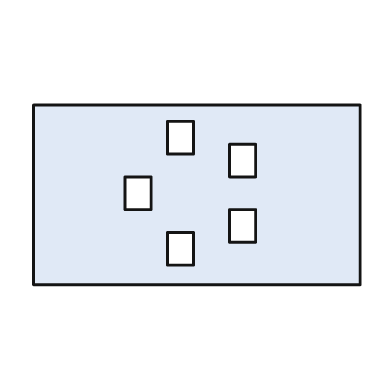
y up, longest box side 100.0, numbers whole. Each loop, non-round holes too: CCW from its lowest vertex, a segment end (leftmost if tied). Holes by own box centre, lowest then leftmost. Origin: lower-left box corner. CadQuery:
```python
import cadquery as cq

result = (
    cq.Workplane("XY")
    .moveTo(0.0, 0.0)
    .lineTo(100.0, 0.0)
    .lineTo(100.0, 55.0)
    .lineTo(0.0, 55.0)
    .close()
    .moveTo(41.0, 6.0)
    .lineTo(49.0, 6.0)
    .lineTo(49.0, 16.0)
    .lineTo(41.0, 16.0)
    .close()
    .moveTo(60.0, 13.0)
    .lineTo(68.0, 13.0)
    .lineTo(68.0, 23.0)
    .lineTo(60.0, 23.0)
    .close()
    .moveTo(28.0, 23.0)
    .lineTo(36.0, 23.0)
    .lineTo(36.0, 33.0)
    .lineTo(28.0, 33.0)
    .close()
    .moveTo(60.0, 33.0)
    .lineTo(68.0, 33.0)
    .lineTo(68.0, 43.0)
    .lineTo(60.0, 43.0)
    .close()
    .moveTo(41.0, 40.0)
    .lineTo(49.0, 40.0)
    .lineTo(49.0, 50.0)
    .lineTo(41.0, 50.0)
    .close()
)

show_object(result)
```